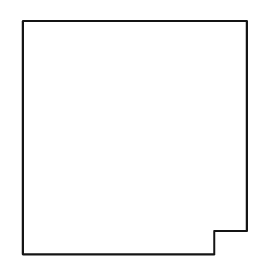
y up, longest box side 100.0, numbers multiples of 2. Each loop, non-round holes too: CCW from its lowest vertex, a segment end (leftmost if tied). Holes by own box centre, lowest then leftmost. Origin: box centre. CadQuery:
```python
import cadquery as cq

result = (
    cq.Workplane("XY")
    .moveTo(-48.0, -50.0)
    .lineTo(34.0, -50.0)
    .lineTo(34.0, -40.0)
    .lineTo(48.0, -40.0)
    .lineTo(48.0, 50.0)
    .lineTo(-48.0, 50.0)
    .close()
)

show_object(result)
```